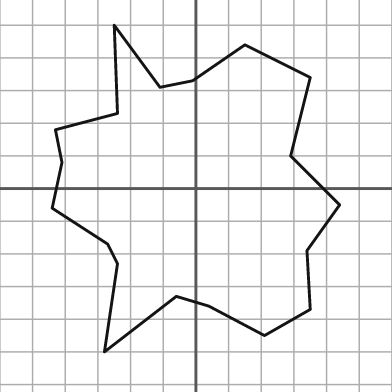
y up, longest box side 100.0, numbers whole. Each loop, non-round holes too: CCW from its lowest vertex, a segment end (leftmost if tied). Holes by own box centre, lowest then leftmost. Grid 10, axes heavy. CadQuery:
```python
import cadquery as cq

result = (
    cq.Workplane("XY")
    .moveTo(-28.0, -50.0)
    .lineTo(-6.0, -33.0)
    .lineTo(4.0, -36.0)
    .lineTo(21.0, -45.0)
    .lineTo(35.0, -37.0)
    .lineTo(34.0, -19.0)
    .lineTo(44.0, -5.0)
    .lineTo(29.0, 10.0)
    .lineTo(35.0, 34.0)
    .lineTo(15.0, 44.0)
    .lineTo(-1.0, 33.0)
    .lineTo(-11.0, 31.0)
    .lineTo(-25.0, 50.0)
    .lineTo(-24.0, 23.0)
    .lineTo(-43.0, 18.0)
    .lineTo(-41.0, 8.0)
    .lineTo(-44.0, -6.0)
    .lineTo(-27.0, -17.0)
    .lineTo(-24.0, -23.0)
    .close()
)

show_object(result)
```